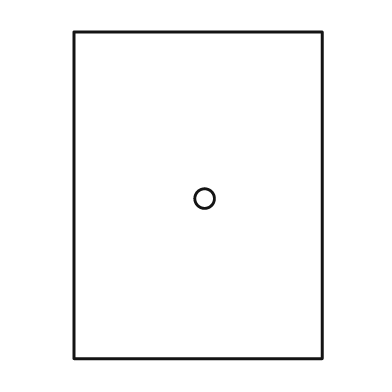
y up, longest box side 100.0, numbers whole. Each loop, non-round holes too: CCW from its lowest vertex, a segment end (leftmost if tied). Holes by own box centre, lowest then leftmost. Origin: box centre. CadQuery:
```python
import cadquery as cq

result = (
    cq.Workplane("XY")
    .moveTo(-38.0, -50.0)
    .lineTo(38.0, -50.0)
    .lineTo(38.0, 50.0)
    .lineTo(-38.0, 50.0)
    .close()
    .moveTo(2.0, -1.0)
    .circle(3.0)
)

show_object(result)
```